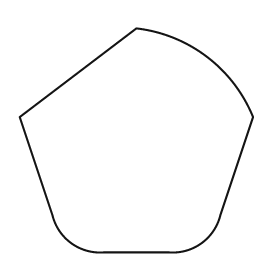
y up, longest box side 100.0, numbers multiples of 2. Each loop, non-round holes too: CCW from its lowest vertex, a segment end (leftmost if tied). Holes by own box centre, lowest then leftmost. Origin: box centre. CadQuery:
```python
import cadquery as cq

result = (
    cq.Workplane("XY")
    .moveTo(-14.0, -48.0)
    .lineTo(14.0, -48.0)
    .threePointArc((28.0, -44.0), (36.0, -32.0))
    .lineTo(50.0, 10.0)
    .threePointArc((30.0, 36.0), (0.0, 48.0))
    .lineTo(-50.0, 10.0)
    .lineTo(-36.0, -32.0)
    .threePointArc((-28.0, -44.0), (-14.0, -48.0))
    .close()
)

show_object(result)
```